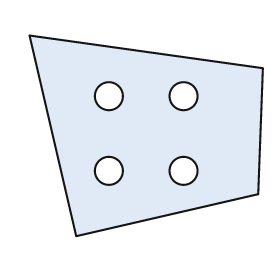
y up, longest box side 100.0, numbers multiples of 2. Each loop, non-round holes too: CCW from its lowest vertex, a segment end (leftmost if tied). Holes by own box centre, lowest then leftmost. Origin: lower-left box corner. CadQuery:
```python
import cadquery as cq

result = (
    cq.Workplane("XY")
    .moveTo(20.0, 0.0)
    .lineTo(98.0, 18.0)
    .lineTo(100.0, 72.0)
    .lineTo(0.0, 86.0)
    .close()
    .moveTo(34.0, 28.0)
    .circle(6.0)
    .moveTo(66.0, 28.0)
    .circle(6.0)
    .moveTo(34.0, 60.0)
    .circle(6.0)
    .moveTo(66.0, 60.0)
    .circle(6.0)
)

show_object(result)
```